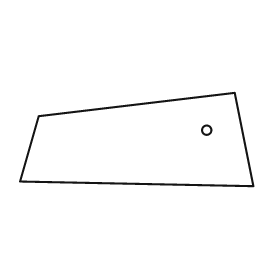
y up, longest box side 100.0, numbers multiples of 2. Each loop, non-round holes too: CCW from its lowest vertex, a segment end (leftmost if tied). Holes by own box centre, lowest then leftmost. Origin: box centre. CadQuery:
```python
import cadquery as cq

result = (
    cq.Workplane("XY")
    .moveTo(50.0, -20.0)
    .lineTo(42.0, 20.0)
    .lineTo(-42.0, 10.0)
    .lineTo(-50.0, -18.0)
    .close()
    .moveTo(30.0, 4.0)
    .circle(2.0)
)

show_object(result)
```